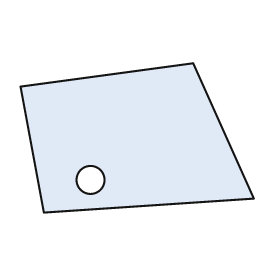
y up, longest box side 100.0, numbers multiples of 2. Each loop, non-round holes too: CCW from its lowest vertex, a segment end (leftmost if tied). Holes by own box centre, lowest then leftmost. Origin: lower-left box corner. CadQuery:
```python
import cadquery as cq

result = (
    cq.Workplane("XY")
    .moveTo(10.0, 0.0)
    .lineTo(100.0, 6.0)
    .lineTo(74.0, 64.0)
    .lineTo(0.0, 54.0)
    .close()
    .moveTo(30.0, 14.0)
    .circle(6.0)
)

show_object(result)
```